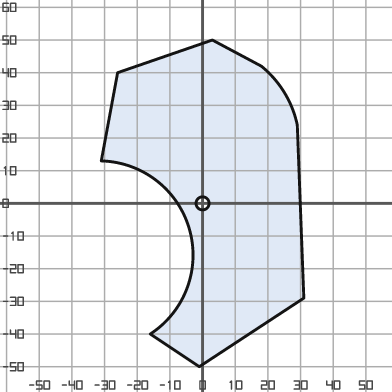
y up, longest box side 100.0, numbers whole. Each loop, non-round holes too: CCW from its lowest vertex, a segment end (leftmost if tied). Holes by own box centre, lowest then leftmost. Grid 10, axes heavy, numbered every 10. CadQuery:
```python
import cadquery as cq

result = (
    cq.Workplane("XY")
    .moveTo(-1.0, -50.0)
    .lineTo(31.0, -29.0)
    .lineTo(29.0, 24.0)
    .threePointArc((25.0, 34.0), (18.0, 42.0))
    .lineTo(3.0, 50.0)
    .lineTo(-26.0, 40.0)
    .lineTo(-31.0, 13.0)
    .threePointArc((-4.0, -8.0), (-16.0, -40.0))
    .close()
    .moveTo(0.0, 0.0)
    .circle(2.0)
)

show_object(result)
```